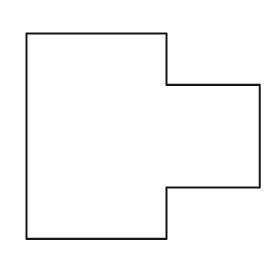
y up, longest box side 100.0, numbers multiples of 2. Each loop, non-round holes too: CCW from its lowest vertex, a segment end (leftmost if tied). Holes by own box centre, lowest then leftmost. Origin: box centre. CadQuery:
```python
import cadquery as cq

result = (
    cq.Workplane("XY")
    .moveTo(-50.0, -44.0)
    .lineTo(10.0, -44.0)
    .lineTo(10.0, -22.0)
    .lineTo(50.0, -22.0)
    .lineTo(50.0, 22.0)
    .lineTo(10.0, 22.0)
    .lineTo(10.0, 44.0)
    .lineTo(-50.0, 44.0)
    .close()
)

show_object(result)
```